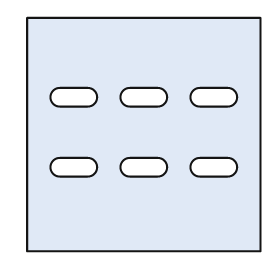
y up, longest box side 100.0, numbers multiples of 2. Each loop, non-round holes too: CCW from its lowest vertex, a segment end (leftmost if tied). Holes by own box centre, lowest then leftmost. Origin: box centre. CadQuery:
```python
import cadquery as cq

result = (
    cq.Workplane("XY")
    .moveTo(-50.0, -50.0)
    .lineTo(50.0, -50.0)
    .lineTo(50.0, 50.0)
    .lineTo(-50.0, 50.0)
    .close()
    .moveTo(-36.0, -18.0)
    .lineTo(-24.0, -18.0)
    .threePointArc((-20.0, -14.0), (-24.0, -10.0))
    .lineTo(-36.0, -10.0)
    .threePointArc((-40.0, -14.0), (-36.0, -18.0))
    .close()
    .moveTo(-6.0, -18.0)
    .lineTo(6.0, -18.0)
    .threePointArc((10.0, -14.0), (6.0, -10.0))
    .lineTo(-6.0, -10.0)
    .threePointArc((-10.0, -14.0), (-6.0, -18.0))
    .close()
    .moveTo(24.0, -18.0)
    .lineTo(36.0, -18.0)
    .threePointArc((40.0, -14.0), (36.0, -10.0))
    .lineTo(24.0, -10.0)
    .threePointArc((20.0, -14.0), (24.0, -18.0))
    .close()
    .moveTo(-36.0, 12.0)
    .lineTo(-24.0, 12.0)
    .threePointArc((-20.0, 16.0), (-24.0, 20.0))
    .lineTo(-36.0, 20.0)
    .threePointArc((-40.0, 16.0), (-36.0, 12.0))
    .close()
    .moveTo(-6.0, 12.0)
    .lineTo(6.0, 12.0)
    .threePointArc((10.0, 16.0), (6.0, 20.0))
    .lineTo(-6.0, 20.0)
    .threePointArc((-10.0, 16.0), (-6.0, 12.0))
    .close()
    .moveTo(24.0, 12.0)
    .lineTo(36.0, 12.0)
    .threePointArc((40.0, 16.0), (36.0, 20.0))
    .lineTo(24.0, 20.0)
    .threePointArc((20.0, 16.0), (24.0, 12.0))
    .close()
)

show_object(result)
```